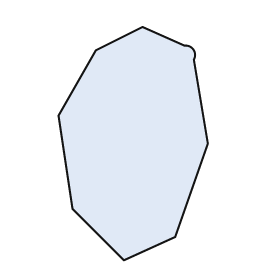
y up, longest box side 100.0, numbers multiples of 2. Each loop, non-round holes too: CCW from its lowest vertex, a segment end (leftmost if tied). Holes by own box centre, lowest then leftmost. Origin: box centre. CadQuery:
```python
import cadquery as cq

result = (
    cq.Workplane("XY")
    .moveTo(-4.0, -50.0)
    .lineTo(18.0, -40.0)
    .lineTo(32.0, 0.0)
    .lineTo(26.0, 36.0)
    .threePointArc((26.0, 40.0), (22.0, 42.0))
    .lineTo(4.0, 50.0)
    .lineTo(-16.0, 40.0)
    .lineTo(-32.0, 12.0)
    .lineTo(-26.0, -28.0)
    .close()
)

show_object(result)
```